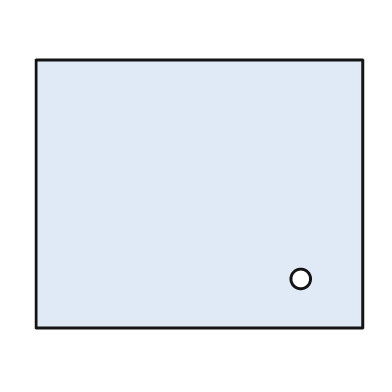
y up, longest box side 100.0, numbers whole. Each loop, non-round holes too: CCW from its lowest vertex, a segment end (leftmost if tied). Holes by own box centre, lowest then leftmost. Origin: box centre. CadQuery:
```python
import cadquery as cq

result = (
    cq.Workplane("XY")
    .moveTo(-50.0, -41.0)
    .lineTo(50.0, -41.0)
    .lineTo(50.0, 41.0)
    .lineTo(-50.0, 41.0)
    .close()
    .moveTo(31.0, -26.0)
    .circle(3.0)
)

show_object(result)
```